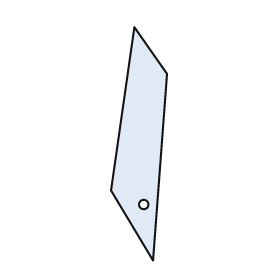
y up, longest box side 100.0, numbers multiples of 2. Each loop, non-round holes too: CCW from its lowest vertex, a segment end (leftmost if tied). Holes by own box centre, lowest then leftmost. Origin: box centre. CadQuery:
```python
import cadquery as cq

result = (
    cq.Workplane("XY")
    .moveTo(6.0, -50.0)
    .lineTo(12.0, 30.0)
    .lineTo(-2.0, 50.0)
    .lineTo(-12.0, -20.0)
    .close()
    .moveTo(2.0, -26.0)
    .circle(2.0)
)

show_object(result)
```